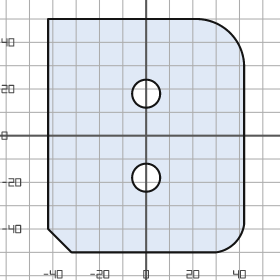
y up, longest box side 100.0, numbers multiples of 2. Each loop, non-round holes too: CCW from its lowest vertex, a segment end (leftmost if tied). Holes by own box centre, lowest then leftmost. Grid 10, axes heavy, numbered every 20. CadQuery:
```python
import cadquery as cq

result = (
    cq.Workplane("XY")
    .moveTo(-32.0, -50.0)
    .lineTo(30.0, -50.0)
    .threePointArc((38.0, -46.0), (42.0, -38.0))
    .lineTo(42.0, 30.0)
    .threePointArc((36.0, 44.0), (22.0, 50.0))
    .lineTo(-42.0, 50.0)
    .lineTo(-42.0, -40.0)
    .close()
    .moveTo(0.0, -18.0)
    .circle(6.0)
    .moveTo(0.0, 18.0)
    .circle(6.0)
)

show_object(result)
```